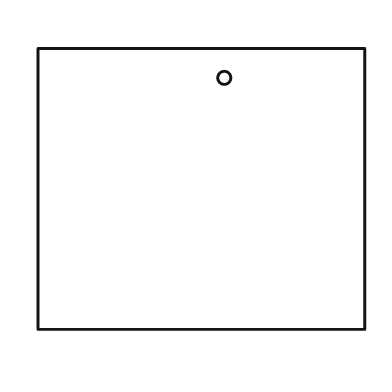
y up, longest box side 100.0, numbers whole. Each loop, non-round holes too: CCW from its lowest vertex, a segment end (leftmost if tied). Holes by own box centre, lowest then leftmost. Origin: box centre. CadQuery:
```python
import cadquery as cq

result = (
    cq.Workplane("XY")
    .moveTo(-50.0, -43.0)
    .lineTo(50.0, -43.0)
    .lineTo(50.0, 43.0)
    .lineTo(-50.0, 43.0)
    .close()
    .moveTo(7.0, 34.0)
    .circle(2.0)
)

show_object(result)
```